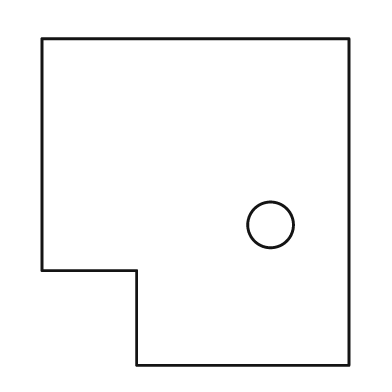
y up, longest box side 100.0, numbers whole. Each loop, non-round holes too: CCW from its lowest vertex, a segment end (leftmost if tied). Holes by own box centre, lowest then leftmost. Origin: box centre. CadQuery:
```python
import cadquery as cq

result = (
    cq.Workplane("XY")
    .moveTo(-18.0, -50.0)
    .lineTo(47.0, -50.0)
    .lineTo(47.0, 50.0)
    .lineTo(-47.0, 50.0)
    .lineTo(-47.0, -21.0)
    .lineTo(-18.0, -21.0)
    .close()
    .moveTo(23.0, -7.0)
    .circle(7.0)
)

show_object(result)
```